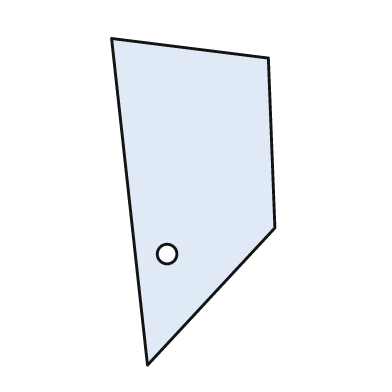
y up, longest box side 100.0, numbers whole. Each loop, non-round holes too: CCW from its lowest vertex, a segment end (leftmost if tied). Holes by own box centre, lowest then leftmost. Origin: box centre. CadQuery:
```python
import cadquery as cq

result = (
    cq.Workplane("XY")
    .moveTo(-14.0, -50.0)
    .lineTo(25.0, -8.0)
    .lineTo(23.0, 44.0)
    .lineTo(-25.0, 50.0)
    .close()
    .moveTo(-8.0, -16.0)
    .circle(3.0)
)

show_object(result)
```